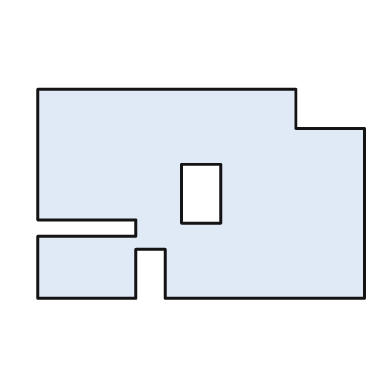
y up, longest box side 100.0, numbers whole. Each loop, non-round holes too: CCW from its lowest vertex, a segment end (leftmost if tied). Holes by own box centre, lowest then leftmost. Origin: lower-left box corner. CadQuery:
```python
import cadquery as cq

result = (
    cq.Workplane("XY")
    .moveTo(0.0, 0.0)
    .lineTo(30.0, 0.0)
    .lineTo(30.0, 15.0)
    .lineTo(39.0, 15.0)
    .lineTo(39.0, 0.0)
    .lineTo(100.0, 0.0)
    .lineTo(100.0, 52.0)
    .lineTo(79.0, 52.0)
    .lineTo(79.0, 64.0)
    .lineTo(0.0, 64.0)
    .lineTo(0.0, 24.0)
    .lineTo(30.0, 24.0)
    .lineTo(30.0, 19.0)
    .lineTo(0.0, 19.0)
    .close()
    .moveTo(44.0, 23.0)
    .lineTo(56.0, 23.0)
    .lineTo(56.0, 41.0)
    .lineTo(44.0, 41.0)
    .close()
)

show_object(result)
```